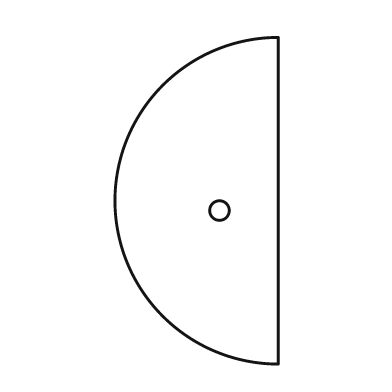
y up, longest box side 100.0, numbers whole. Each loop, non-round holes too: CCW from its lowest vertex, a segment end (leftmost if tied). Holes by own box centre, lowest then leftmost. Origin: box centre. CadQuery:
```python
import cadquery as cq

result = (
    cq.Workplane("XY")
    .moveTo(25.0, -50.0)
    .lineTo(25.0, 50.0)
    .threePointArc((-25.0, 0.0), (25.0, -50.0))
    .close()
    .moveTo(7.0, -3.0)
    .circle(3.0)
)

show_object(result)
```